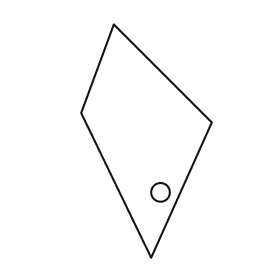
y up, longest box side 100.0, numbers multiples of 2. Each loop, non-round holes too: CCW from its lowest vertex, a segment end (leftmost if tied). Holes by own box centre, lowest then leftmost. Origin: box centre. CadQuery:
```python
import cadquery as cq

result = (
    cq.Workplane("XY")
    .moveTo(2.0, -50.0)
    .lineTo(28.0, 8.0)
    .lineTo(-14.0, 50.0)
    .lineTo(-28.0, 12.0)
    .close()
    .moveTo(6.0, -22.0)
    .circle(4.0)
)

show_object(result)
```